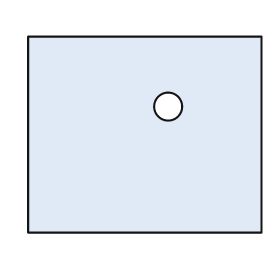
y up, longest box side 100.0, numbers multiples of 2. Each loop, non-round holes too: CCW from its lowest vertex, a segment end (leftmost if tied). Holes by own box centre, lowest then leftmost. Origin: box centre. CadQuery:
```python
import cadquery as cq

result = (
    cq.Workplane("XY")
    .moveTo(-50.0, -42.0)
    .lineTo(50.0, -42.0)
    .lineTo(50.0, 42.0)
    .lineTo(-50.0, 42.0)
    .close()
    .moveTo(10.0, 12.0)
    .circle(6.0)
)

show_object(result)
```